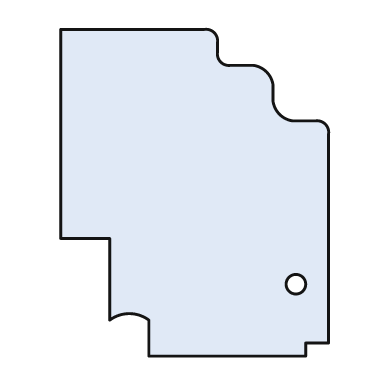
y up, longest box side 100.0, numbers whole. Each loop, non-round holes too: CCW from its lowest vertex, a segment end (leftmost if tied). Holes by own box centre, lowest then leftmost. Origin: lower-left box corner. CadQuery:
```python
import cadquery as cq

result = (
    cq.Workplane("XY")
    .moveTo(27.0, 0.0)
    .lineTo(75.0, 0.0)
    .lineTo(75.0, 4.0)
    .lineTo(82.0, 4.0)
    .lineTo(82.0, 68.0)
    .threePointArc((81.0, 71.0), (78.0, 72.0))
    .lineTo(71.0, 72.0)
    .threePointArc((67.0, 74.0), (65.0, 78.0))
    .lineTo(65.0, 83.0)
    .threePointArc((63.0, 87.0), (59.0, 89.0))
    .lineTo(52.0, 89.0)
    .threePointArc((49.0, 90.0), (48.0, 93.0))
    .lineTo(48.0, 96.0)
    .threePointArc((47.0, 99.0), (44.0, 100.0))
    .lineTo(0.0, 100.0)
    .lineTo(0.0, 36.0)
    .lineTo(15.0, 36.0)
    .lineTo(15.0, 11.0)
    .threePointArc((21.0, 13.0), (27.0, 11.0))
    .close()
    .moveTo(72.0, 22.0)
    .circle(3.0)
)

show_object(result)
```